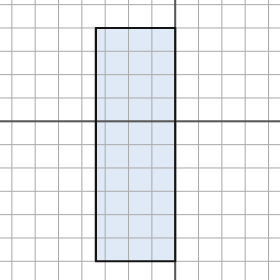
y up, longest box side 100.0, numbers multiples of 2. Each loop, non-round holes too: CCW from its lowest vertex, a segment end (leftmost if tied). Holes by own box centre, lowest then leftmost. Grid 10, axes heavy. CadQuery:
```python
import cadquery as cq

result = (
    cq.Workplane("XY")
    .moveTo(-34.0, -60.0)
    .lineTo(0.0, -60.0)
    .lineTo(0.0, 40.0)
    .lineTo(-34.0, 40.0)
    .close()
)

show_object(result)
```